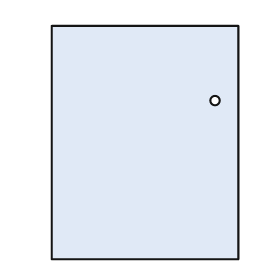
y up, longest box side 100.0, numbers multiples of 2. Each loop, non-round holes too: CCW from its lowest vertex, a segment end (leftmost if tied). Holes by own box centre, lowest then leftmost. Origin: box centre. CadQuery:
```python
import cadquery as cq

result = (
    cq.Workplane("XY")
    .moveTo(-40.0, -50.0)
    .lineTo(40.0, -50.0)
    .lineTo(40.0, 50.0)
    .lineTo(-40.0, 50.0)
    .close()
    .moveTo(30.0, 18.0)
    .circle(2.0)
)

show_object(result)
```